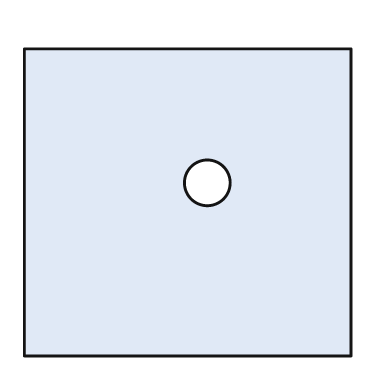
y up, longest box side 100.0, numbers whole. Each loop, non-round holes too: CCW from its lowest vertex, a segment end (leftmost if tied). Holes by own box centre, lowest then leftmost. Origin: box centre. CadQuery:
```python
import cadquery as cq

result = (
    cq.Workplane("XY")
    .moveTo(-50.0, -47.0)
    .lineTo(50.0, -47.0)
    .lineTo(50.0, 47.0)
    .lineTo(-50.0, 47.0)
    .close()
    .moveTo(6.0, 6.0)
    .circle(7.0)
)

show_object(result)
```